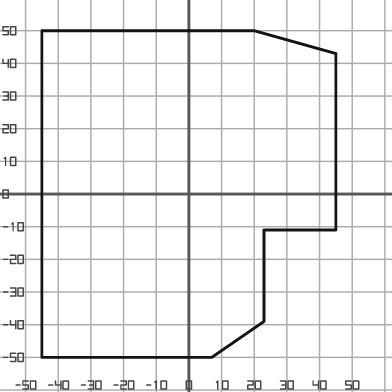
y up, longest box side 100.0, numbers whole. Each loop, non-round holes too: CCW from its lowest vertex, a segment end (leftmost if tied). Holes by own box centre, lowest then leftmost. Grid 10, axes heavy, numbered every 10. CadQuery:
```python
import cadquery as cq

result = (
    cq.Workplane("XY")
    .moveTo(-45.0, -50.0)
    .lineTo(7.0, -50.0)
    .lineTo(23.0, -39.0)
    .lineTo(23.0, -11.0)
    .lineTo(45.0, -11.0)
    .lineTo(45.0, 43.0)
    .lineTo(20.0, 50.0)
    .lineTo(-45.0, 50.0)
    .close()
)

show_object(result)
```